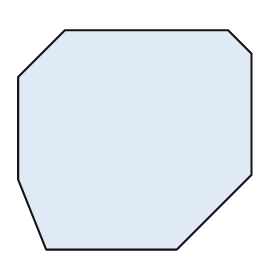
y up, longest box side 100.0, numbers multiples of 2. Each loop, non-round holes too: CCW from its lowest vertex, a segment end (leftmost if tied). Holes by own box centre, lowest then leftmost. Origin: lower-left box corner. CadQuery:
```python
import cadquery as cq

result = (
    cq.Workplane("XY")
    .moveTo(12.0, 0.0)
    .lineTo(68.0, 0.0)
    .lineTo(100.0, 32.0)
    .lineTo(100.0, 84.0)
    .lineTo(90.0, 94.0)
    .lineTo(20.0, 94.0)
    .lineTo(0.0, 74.0)
    .lineTo(0.0, 30.0)
    .close()
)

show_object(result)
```